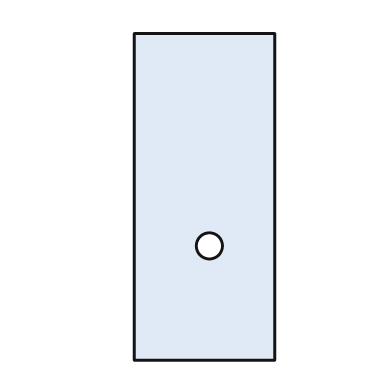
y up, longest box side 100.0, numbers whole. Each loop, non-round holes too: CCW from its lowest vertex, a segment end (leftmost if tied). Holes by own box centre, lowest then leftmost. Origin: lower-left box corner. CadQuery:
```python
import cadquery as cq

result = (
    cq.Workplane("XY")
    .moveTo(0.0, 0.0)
    .lineTo(43.0, 0.0)
    .lineTo(43.0, 100.0)
    .lineTo(0.0, 100.0)
    .close()
    .moveTo(23.0, 35.0)
    .circle(4.0)
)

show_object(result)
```